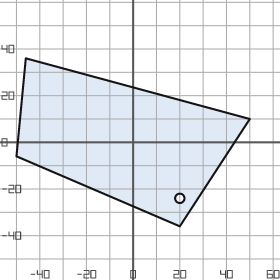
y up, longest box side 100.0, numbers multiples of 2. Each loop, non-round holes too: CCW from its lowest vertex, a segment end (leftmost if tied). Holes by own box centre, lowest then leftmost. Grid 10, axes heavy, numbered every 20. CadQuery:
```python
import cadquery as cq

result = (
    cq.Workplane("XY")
    .moveTo(20.0, -36.0)
    .lineTo(50.0, 10.0)
    .lineTo(-46.0, 36.0)
    .lineTo(-50.0, -6.0)
    .close()
    .moveTo(20.0, -24.0)
    .circle(2.0)
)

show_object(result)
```